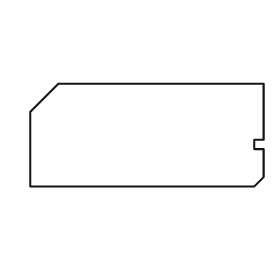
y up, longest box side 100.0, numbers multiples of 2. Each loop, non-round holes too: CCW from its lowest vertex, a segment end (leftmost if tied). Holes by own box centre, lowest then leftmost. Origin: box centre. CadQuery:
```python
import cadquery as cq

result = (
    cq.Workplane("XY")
    .moveTo(-50.0, -22.0)
    .lineTo(46.0, -22.0)
    .lineTo(50.0, -18.0)
    .lineTo(50.0, -6.0)
    .lineTo(46.0, -6.0)
    .lineTo(46.0, -2.0)
    .lineTo(50.0, -2.0)
    .lineTo(50.0, 22.0)
    .lineTo(-38.0, 22.0)
    .lineTo(-50.0, 10.0)
    .close()
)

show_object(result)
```